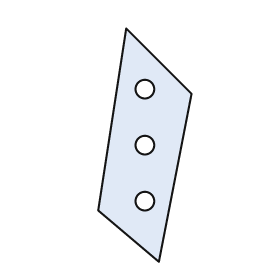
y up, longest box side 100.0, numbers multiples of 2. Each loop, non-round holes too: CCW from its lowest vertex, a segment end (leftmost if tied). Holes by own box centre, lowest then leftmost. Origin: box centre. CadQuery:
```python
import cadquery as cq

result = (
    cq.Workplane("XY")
    .moveTo(6.0, -50.0)
    .lineTo(20.0, 22.0)
    .lineTo(-8.0, 50.0)
    .lineTo(-20.0, -28.0)
    .close()
    .moveTo(0.0, -24.0)
    .circle(4.0)
    .moveTo(0.0, 0.0)
    .circle(4.0)
    .moveTo(0.0, 24.0)
    .circle(4.0)
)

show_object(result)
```